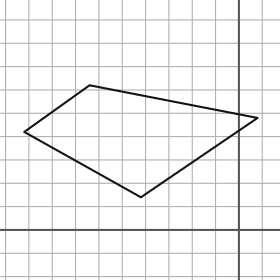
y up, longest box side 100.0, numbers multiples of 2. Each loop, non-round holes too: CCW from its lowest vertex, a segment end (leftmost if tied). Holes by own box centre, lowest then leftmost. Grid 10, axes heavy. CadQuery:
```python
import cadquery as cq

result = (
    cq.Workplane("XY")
    .moveTo(-42.0, 14.0)
    .lineTo(8.0, 48.0)
    .lineTo(-64.0, 62.0)
    .lineTo(-92.0, 42.0)
    .close()
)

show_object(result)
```